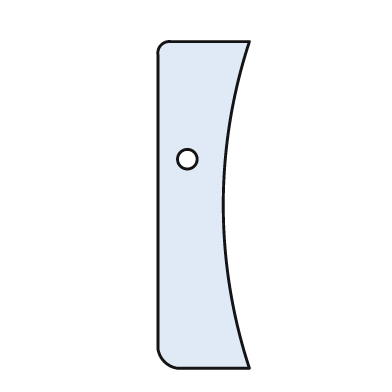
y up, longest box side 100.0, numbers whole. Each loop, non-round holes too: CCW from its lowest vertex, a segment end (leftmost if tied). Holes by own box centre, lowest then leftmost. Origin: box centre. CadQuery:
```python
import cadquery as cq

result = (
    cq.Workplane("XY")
    .moveTo(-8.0, -50.0)
    .lineTo(14.0, -50.0)
    .threePointArc((6.0, 0.0), (14.0, 50.0))
    .lineTo(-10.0, 50.0)
    .threePointArc((-13.0, 49.0), (-14.0, 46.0))
    .lineTo(-14.0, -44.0)
    .threePointArc((-12.0, -48.0), (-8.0, -50.0))
    .close()
    .moveTo(-5.0, 14.0)
    .circle(3.0)
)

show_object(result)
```